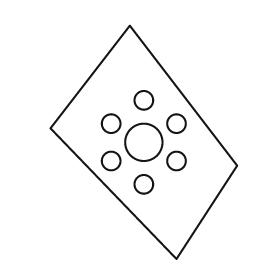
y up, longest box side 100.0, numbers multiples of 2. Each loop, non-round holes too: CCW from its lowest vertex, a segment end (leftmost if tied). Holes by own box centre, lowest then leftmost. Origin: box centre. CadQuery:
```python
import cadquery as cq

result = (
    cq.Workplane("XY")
    .moveTo(14.0, -50.0)
    .lineTo(40.0, -10.0)
    .lineTo(-6.0, 50.0)
    .lineTo(-40.0, 6.0)
    .close()
    .moveTo(0.0, -18.0)
    .circle(4.0)
    .moveTo(-14.0, -8.0)
    .circle(4.0)
    .moveTo(14.0, -8.0)
    .circle(4.0)
    .moveTo(0.0, 0.0)
    .circle(8.0)
    .moveTo(-14.0, 8.0)
    .circle(4.0)
    .moveTo(14.0, 8.0)
    .circle(4.0)
    .moveTo(0.0, 18.0)
    .circle(4.0)
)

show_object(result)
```